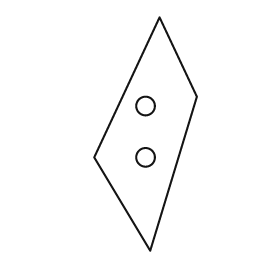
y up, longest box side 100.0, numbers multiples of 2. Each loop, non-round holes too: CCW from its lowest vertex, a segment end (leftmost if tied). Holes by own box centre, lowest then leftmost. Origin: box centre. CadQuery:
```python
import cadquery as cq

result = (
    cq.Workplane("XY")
    .moveTo(2.0, -50.0)
    .lineTo(22.0, 16.0)
    .lineTo(6.0, 50.0)
    .lineTo(-22.0, -10.0)
    .close()
    .moveTo(0.0, -10.0)
    .circle(4.0)
    .moveTo(0.0, 12.0)
    .circle(4.0)
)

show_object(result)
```